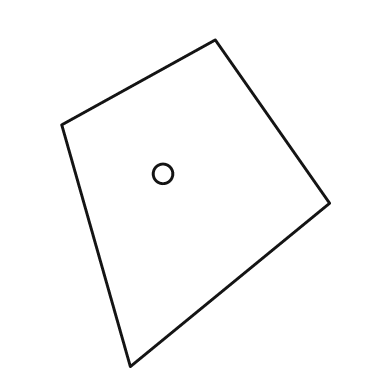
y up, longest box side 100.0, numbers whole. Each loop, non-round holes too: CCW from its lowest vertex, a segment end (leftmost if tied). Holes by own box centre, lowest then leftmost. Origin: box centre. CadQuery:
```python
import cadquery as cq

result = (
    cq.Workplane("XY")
    .moveTo(-20.0, -50.0)
    .lineTo(41.0, 0.0)
    .lineTo(6.0, 50.0)
    .lineTo(-41.0, 24.0)
    .close()
    .moveTo(-10.0, 9.0)
    .circle(3.0)
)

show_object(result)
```